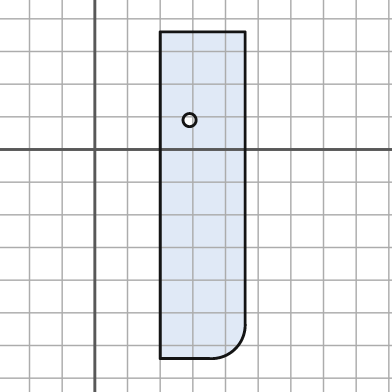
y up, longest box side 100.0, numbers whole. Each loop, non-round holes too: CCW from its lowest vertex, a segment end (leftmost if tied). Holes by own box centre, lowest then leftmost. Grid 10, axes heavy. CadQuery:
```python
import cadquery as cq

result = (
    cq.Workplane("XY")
    .moveTo(20.0, -64.0)
    .lineTo(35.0, -64.0)
    .threePointArc((43.0, -61.0), (46.0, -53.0))
    .lineTo(46.0, 36.0)
    .lineTo(20.0, 36.0)
    .close()
    .moveTo(29.0, 9.0)
    .circle(2.0)
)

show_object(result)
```